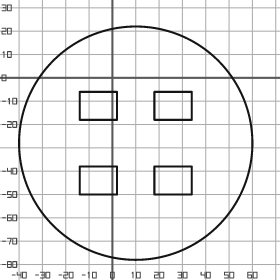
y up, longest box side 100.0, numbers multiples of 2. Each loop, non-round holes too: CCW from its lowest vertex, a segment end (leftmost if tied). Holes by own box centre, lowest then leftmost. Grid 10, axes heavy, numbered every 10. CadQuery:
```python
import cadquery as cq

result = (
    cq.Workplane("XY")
    .moveTo(10.0, -28.0)
    .circle(50.0)
    .moveTo(-14.0, -50.0)
    .lineTo(2.0, -50.0)
    .lineTo(2.0, -38.0)
    .lineTo(-14.0, -38.0)
    .close()
    .moveTo(18.0, -50.0)
    .lineTo(34.0, -50.0)
    .lineTo(34.0, -38.0)
    .lineTo(18.0, -38.0)
    .close()
    .moveTo(-14.0, -18.0)
    .lineTo(2.0, -18.0)
    .lineTo(2.0, -6.0)
    .lineTo(-14.0, -6.0)
    .close()
    .moveTo(18.0, -18.0)
    .lineTo(34.0, -18.0)
    .lineTo(34.0, -6.0)
    .lineTo(18.0, -6.0)
    .close()
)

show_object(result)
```